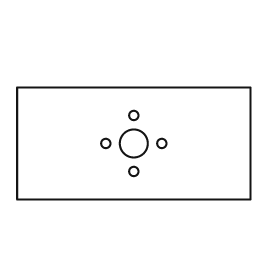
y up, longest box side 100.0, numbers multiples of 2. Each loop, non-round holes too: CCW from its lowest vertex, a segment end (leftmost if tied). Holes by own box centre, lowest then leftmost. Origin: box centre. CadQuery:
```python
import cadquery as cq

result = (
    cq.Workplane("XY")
    .moveTo(-50.0, -24.0)
    .lineTo(50.0, -24.0)
    .lineTo(50.0, 24.0)
    .lineTo(-50.0, 24.0)
    .close()
    .moveTo(0.0, -12.0)
    .circle(2.0)
    .moveTo(-12.0, 0.0)
    .circle(2.0)
    .moveTo(0.0, 0.0)
    .circle(6.0)
    .moveTo(12.0, 0.0)
    .circle(2.0)
    .moveTo(0.0, 12.0)
    .circle(2.0)
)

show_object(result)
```